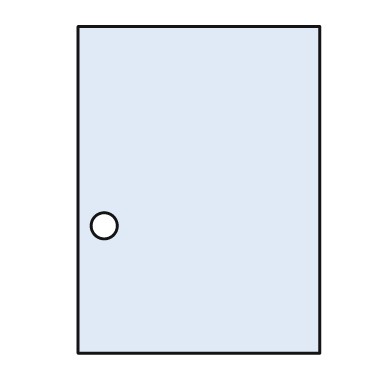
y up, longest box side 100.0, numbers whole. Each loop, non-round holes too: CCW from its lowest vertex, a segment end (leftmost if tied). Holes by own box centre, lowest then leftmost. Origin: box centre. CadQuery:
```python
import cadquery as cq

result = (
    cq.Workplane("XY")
    .moveTo(-37.0, -50.0)
    .lineTo(37.0, -50.0)
    .lineTo(37.0, 50.0)
    .lineTo(-37.0, 50.0)
    .close()
    .moveTo(-29.0, -11.0)
    .circle(4.0)
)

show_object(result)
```